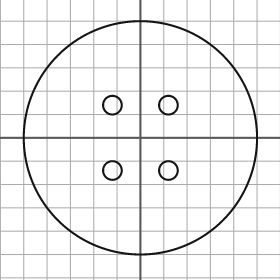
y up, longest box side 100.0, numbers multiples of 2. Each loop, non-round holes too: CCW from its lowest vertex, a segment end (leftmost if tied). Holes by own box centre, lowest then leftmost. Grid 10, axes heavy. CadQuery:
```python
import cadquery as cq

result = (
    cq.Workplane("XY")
    .moveTo(0.0, 0.0)
    .circle(50.0)
    .moveTo(-12.0, -14.0)
    .circle(4.0)
    .moveTo(12.0, -14.0)
    .circle(4.0)
    .moveTo(-12.0, 14.0)
    .circle(4.0)
    .moveTo(12.0, 14.0)
    .circle(4.0)
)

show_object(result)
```